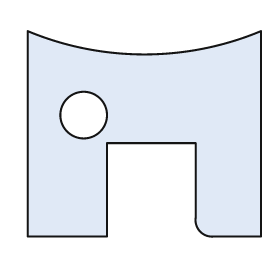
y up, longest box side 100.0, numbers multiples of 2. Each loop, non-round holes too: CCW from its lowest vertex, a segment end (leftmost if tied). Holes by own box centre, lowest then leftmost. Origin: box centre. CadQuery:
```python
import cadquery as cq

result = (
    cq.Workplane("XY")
    .moveTo(-50.0, -44.0)
    .lineTo(-16.0, -44.0)
    .lineTo(-16.0, -4.0)
    .lineTo(22.0, -4.0)
    .lineTo(22.0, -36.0)
    .threePointArc((24.0, -42.0), (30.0, -44.0))
    .lineTo(50.0, -44.0)
    .lineTo(50.0, 44.0)
    .threePointArc((0.0, 34.0), (-50.0, 44.0))
    .close()
    .moveTo(-26.0, 8.0)
    .circle(10.0)
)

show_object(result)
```